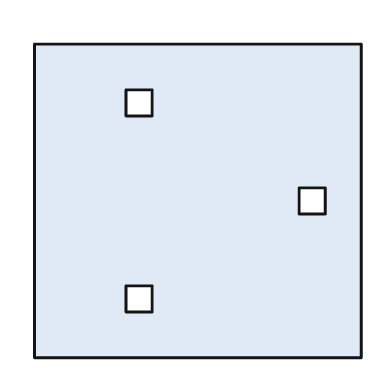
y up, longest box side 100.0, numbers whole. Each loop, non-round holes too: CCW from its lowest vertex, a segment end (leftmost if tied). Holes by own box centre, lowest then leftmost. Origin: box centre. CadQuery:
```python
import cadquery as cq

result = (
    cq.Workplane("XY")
    .moveTo(-50.0, -48.0)
    .lineTo(50.0, -48.0)
    .lineTo(50.0, 48.0)
    .lineTo(-50.0, 48.0)
    .close()
    .moveTo(-22.0, -34.0)
    .lineTo(-14.0, -34.0)
    .lineTo(-14.0, -26.0)
    .lineTo(-22.0, -26.0)
    .close()
    .moveTo(31.0, -4.0)
    .lineTo(39.0, -4.0)
    .lineTo(39.0, 4.0)
    .lineTo(31.0, 4.0)
    .close()
    .moveTo(-22.0, 26.0)
    .lineTo(-14.0, 26.0)
    .lineTo(-14.0, 34.0)
    .lineTo(-22.0, 34.0)
    .close()
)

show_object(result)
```